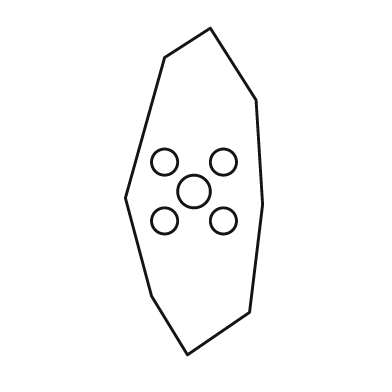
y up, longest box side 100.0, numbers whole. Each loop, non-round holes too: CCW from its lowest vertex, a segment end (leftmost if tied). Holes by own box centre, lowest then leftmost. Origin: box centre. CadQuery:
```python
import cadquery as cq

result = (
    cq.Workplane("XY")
    .moveTo(-2.0, -50.0)
    .lineTo(17.0, -37.0)
    .lineTo(21.0, -4.0)
    .lineTo(19.0, 28.0)
    .lineTo(5.0, 50.0)
    .lineTo(-9.0, 41.0)
    .lineTo(-21.0, -2.0)
    .lineTo(-13.0, -32.0)
    .close()
    .moveTo(-9.0, -9.0)
    .circle(4.0)
    .moveTo(9.0, -9.0)
    .circle(4.0)
    .moveTo(0.0, 0.0)
    .circle(5.0)
    .moveTo(-9.0, 9.0)
    .circle(4.0)
    .moveTo(9.0, 9.0)
    .circle(4.0)
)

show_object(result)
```